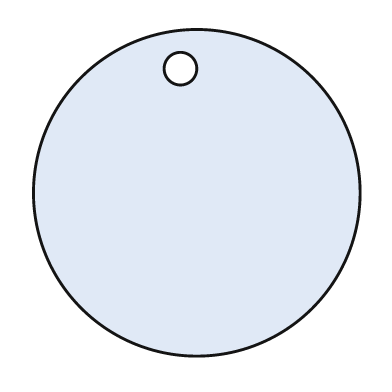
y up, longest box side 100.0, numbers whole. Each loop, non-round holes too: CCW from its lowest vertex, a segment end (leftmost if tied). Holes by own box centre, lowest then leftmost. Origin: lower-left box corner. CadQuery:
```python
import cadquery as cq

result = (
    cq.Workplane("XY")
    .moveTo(50.0, 50.0)
    .circle(50.0)
    .moveTo(45.0, 88.0)
    .circle(5.0)
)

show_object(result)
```